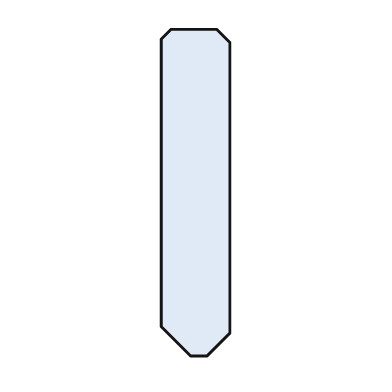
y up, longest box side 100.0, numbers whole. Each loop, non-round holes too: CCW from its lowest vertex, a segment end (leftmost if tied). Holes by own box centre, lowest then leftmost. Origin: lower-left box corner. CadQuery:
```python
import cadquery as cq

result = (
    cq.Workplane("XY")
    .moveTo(9.0, 0.0)
    .lineTo(14.0, 0.0)
    .lineTo(21.0, 7.0)
    .lineTo(21.0, 96.0)
    .lineTo(17.0, 100.0)
    .lineTo(3.0, 100.0)
    .lineTo(0.0, 97.0)
    .lineTo(0.0, 9.0)
    .close()
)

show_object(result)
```